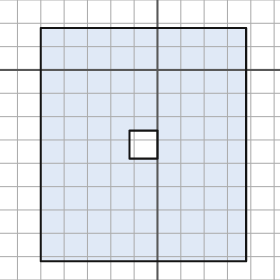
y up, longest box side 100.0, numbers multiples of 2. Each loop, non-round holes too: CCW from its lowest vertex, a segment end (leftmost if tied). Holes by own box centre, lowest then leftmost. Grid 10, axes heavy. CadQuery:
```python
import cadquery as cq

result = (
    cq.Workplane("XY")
    .moveTo(-50.0, -82.0)
    .lineTo(38.0, -82.0)
    .lineTo(38.0, 18.0)
    .lineTo(-50.0, 18.0)
    .close()
    .moveTo(-12.0, -38.0)
    .lineTo(0.0, -38.0)
    .lineTo(0.0, -26.0)
    .lineTo(-12.0, -26.0)
    .close()
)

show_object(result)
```